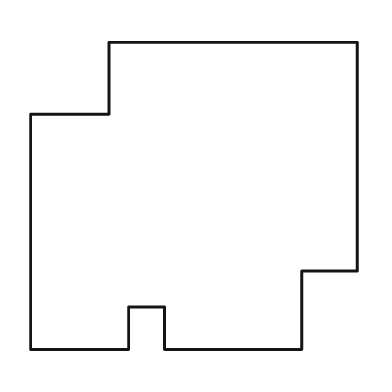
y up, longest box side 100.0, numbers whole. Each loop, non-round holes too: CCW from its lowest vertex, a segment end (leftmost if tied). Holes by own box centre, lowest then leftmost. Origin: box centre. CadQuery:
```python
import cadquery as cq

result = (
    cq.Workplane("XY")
    .moveTo(-50.0, -47.0)
    .lineTo(-20.0, -47.0)
    .lineTo(-20.0, -34.0)
    .lineTo(-9.0, -34.0)
    .lineTo(-9.0, -47.0)
    .lineTo(33.0, -47.0)
    .lineTo(33.0, -23.0)
    .lineTo(50.0, -23.0)
    .lineTo(50.0, 47.0)
    .lineTo(-26.0, 47.0)
    .lineTo(-26.0, 25.0)
    .lineTo(-50.0, 25.0)
    .close()
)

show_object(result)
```